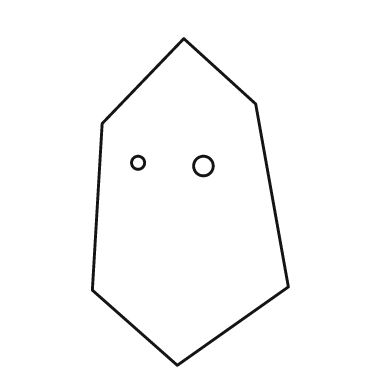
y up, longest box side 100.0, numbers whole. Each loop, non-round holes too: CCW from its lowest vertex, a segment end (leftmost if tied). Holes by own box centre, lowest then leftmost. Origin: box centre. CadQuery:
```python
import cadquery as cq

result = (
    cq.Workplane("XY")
    .moveTo(-4.0, -50.0)
    .lineTo(30.0, -26.0)
    .lineTo(20.0, 30.0)
    .lineTo(-2.0, 50.0)
    .lineTo(-27.0, 24.0)
    .lineTo(-30.0, -27.0)
    .close()
    .moveTo(4.0, 11.0)
    .circle(3.0)
    .moveTo(-16.0, 12.0)
    .circle(2.0)
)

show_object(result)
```